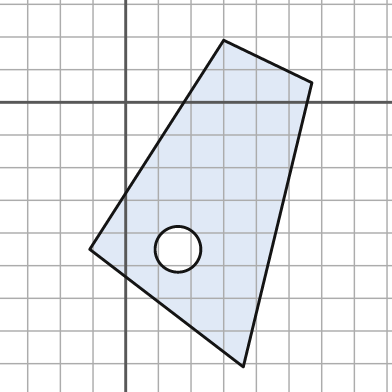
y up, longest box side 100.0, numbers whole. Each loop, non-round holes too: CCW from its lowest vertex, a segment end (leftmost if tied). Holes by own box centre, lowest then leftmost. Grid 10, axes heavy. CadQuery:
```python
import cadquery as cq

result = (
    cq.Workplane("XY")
    .moveTo(36.0, -81.0)
    .lineTo(57.0, 6.0)
    .lineTo(30.0, 19.0)
    .lineTo(-11.0, -45.0)
    .close()
    .moveTo(16.0, -45.0)
    .circle(7.0)
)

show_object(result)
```